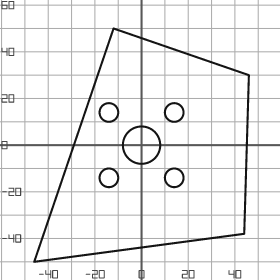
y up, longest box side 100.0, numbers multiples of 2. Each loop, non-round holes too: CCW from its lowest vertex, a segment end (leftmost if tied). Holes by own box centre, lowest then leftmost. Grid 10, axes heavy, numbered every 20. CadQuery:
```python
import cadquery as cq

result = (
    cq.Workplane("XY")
    .moveTo(-46.0, -50.0)
    .lineTo(44.0, -38.0)
    .lineTo(46.0, 30.0)
    .lineTo(-12.0, 50.0)
    .close()
    .moveTo(-14.0, -14.0)
    .circle(4.0)
    .moveTo(14.0, -14.0)
    .circle(4.0)
    .moveTo(0.0, 0.0)
    .circle(8.0)
    .moveTo(-14.0, 14.0)
    .circle(4.0)
    .moveTo(14.0, 14.0)
    .circle(4.0)
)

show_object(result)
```